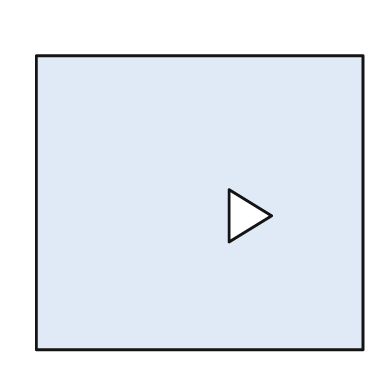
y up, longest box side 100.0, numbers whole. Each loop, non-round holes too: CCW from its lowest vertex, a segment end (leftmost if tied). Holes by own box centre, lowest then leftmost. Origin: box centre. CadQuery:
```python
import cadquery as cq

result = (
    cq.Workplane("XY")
    .moveTo(-50.0, -45.0)
    .lineTo(50.0, -45.0)
    .lineTo(50.0, 45.0)
    .lineTo(-50.0, 45.0)
    .close()
    .moveTo(9.0, -12.0)
    .lineTo(22.0, -4.0)
    .lineTo(9.0, 4.0)
    .close()
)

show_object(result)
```